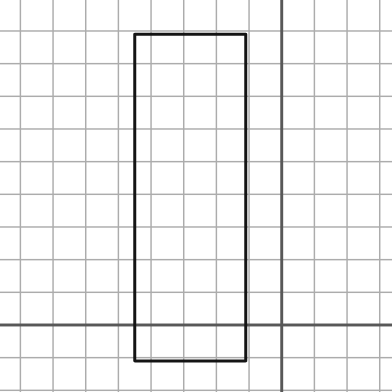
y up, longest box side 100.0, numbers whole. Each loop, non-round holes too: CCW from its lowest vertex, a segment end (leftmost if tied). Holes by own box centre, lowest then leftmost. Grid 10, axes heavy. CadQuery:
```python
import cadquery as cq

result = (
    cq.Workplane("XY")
    .moveTo(-45.0, -11.0)
    .lineTo(-11.0, -11.0)
    .lineTo(-11.0, 89.0)
    .lineTo(-45.0, 89.0)
    .close()
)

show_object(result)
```